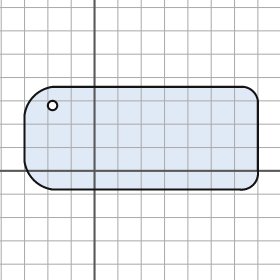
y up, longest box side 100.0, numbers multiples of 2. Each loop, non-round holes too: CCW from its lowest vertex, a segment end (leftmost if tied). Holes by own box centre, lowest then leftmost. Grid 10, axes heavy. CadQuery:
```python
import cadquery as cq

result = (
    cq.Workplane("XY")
    .moveTo(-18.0, -8.0)
    .lineTo(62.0, -8.0)
    .threePointArc((68.0, -6.0), (70.0, 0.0))
    .lineTo(70.0, 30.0)
    .threePointArc((68.0, 34.0), (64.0, 36.0))
    .lineTo(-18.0, 36.0)
    .threePointArc((-26.0, 32.0), (-30.0, 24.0))
    .lineTo(-30.0, 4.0)
    .threePointArc((-26.0, -4.0), (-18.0, -8.0))
    .close()
    .moveTo(-18.0, 28.0)
    .circle(2.0)
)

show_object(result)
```